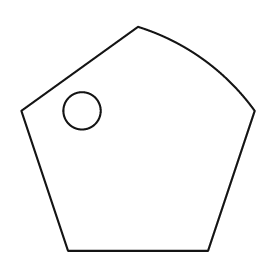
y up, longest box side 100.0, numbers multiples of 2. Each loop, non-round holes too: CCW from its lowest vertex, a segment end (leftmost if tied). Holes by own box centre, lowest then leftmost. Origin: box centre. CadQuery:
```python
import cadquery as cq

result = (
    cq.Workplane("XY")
    .moveTo(-30.0, -48.0)
    .lineTo(30.0, -48.0)
    .lineTo(50.0, 12.0)
    .threePointArc((28.0, 34.0), (0.0, 48.0))
    .lineTo(-50.0, 12.0)
    .close()
    .moveTo(-24.0, 12.0)
    .circle(8.0)
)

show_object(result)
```